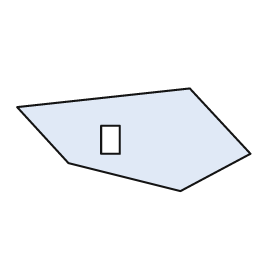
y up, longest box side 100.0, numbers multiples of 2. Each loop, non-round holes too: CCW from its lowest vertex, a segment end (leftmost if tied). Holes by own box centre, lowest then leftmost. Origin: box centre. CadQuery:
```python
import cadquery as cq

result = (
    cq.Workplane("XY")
    .moveTo(20.0, -22.0)
    .lineTo(50.0, -6.0)
    .lineTo(24.0, 22.0)
    .lineTo(-50.0, 14.0)
    .lineTo(-28.0, -10.0)
    .close()
    .moveTo(-14.0, -6.0)
    .lineTo(-6.0, -6.0)
    .lineTo(-6.0, 6.0)
    .lineTo(-14.0, 6.0)
    .close()
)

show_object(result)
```